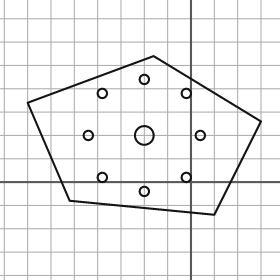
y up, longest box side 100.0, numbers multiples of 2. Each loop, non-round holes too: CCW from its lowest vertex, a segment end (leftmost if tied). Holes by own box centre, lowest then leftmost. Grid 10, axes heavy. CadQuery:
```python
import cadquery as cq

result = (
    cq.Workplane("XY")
    .moveTo(10.0, -14.0)
    .lineTo(30.0, 26.0)
    .lineTo(-16.0, 54.0)
    .lineTo(-70.0, 34.0)
    .lineTo(-52.0, -8.0)
    .close()
    .moveTo(-20.0, -4.0)
    .circle(2.0)
    .moveTo(-38.0, 2.0)
    .circle(2.0)
    .moveTo(-2.0, 2.0)
    .circle(2.0)
    .moveTo(-44.0, 20.0)
    .circle(2.0)
    .moveTo(-20.0, 20.0)
    .circle(4.0)
    .moveTo(4.0, 20.0)
    .circle(2.0)
    .moveTo(-38.0, 38.0)
    .circle(2.0)
    .moveTo(-2.0, 38.0)
    .circle(2.0)
    .moveTo(-20.0, 44.0)
    .circle(2.0)
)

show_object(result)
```